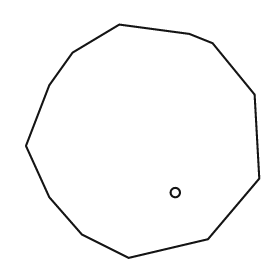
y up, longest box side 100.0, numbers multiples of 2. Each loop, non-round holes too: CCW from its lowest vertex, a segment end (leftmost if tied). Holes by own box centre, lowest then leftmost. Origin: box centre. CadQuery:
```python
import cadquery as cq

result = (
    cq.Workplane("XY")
    .moveTo(-6.0, -50.0)
    .lineTo(28.0, -42.0)
    .lineTo(50.0, -16.0)
    .lineTo(48.0, 20.0)
    .lineTo(30.0, 42.0)
    .lineTo(20.0, 46.0)
    .lineTo(-10.0, 50.0)
    .lineTo(-30.0, 38.0)
    .lineTo(-40.0, 24.0)
    .lineTo(-50.0, -2.0)
    .lineTo(-40.0, -24.0)
    .lineTo(-26.0, -40.0)
    .close()
    .moveTo(14.0, -22.0)
    .circle(2.0)
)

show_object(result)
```